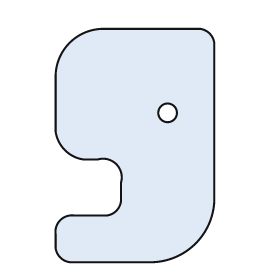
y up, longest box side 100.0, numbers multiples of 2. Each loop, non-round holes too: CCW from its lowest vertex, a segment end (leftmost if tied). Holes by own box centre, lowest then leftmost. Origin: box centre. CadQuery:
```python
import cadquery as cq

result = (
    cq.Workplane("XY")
    .moveTo(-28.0, -50.0)
    .lineTo(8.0, -50.0)
    .threePointArc((26.0, -42.0), (34.0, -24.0))
    .lineTo(34.0, 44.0)
    .threePointArc((32.0, 48.0), (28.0, 50.0))
    .lineTo(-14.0, 50.0)
    .threePointArc((-28.0, 44.0), (-34.0, 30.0))
    .lineTo(-34.0, 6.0)
    .threePointArc((-30.0, -2.0), (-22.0, -6.0))
    .lineTo(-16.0, -6.0)
    .threePointArc((-8.0, -8.0), (-6.0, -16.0))
    .lineTo(-6.0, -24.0)
    .threePointArc((-8.0, -28.0), (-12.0, -30.0))
    .lineTo(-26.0, -30.0)
    .threePointArc((-32.0, -32.0), (-34.0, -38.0))
    .lineTo(-34.0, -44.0)
    .threePointArc((-32.0, -48.0), (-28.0, -50.0))
    .close()
    .moveTo(14.0, 14.0)
    .circle(4.0)
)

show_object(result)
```